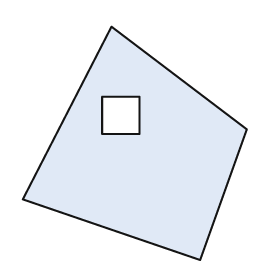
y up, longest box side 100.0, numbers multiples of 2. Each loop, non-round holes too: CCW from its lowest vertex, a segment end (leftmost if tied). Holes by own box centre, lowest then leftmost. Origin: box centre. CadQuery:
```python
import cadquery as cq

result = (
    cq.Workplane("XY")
    .moveTo(28.0, -50.0)
    .lineTo(48.0, 6.0)
    .lineTo(-10.0, 50.0)
    .lineTo(-48.0, -24.0)
    .close()
    .moveTo(-14.0, 4.0)
    .lineTo(2.0, 4.0)
    .lineTo(2.0, 20.0)
    .lineTo(-14.0, 20.0)
    .close()
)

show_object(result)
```